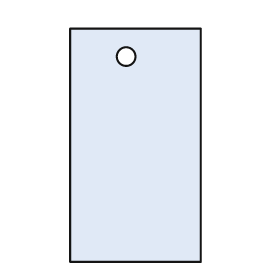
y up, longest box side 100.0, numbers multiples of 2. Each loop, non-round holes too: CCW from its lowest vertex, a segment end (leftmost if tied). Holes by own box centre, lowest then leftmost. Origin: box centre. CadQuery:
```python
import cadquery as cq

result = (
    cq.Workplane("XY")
    .moveTo(-28.0, -50.0)
    .lineTo(28.0, -50.0)
    .lineTo(28.0, 50.0)
    .lineTo(-28.0, 50.0)
    .close()
    .moveTo(-4.0, 38.0)
    .circle(4.0)
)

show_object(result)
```